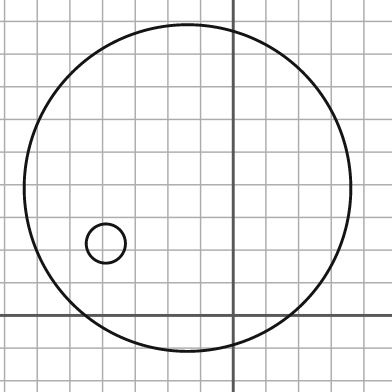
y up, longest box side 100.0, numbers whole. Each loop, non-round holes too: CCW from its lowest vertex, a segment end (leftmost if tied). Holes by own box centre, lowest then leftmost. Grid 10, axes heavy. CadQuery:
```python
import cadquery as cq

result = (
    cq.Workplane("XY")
    .moveTo(-14.0, 39.0)
    .circle(50.0)
    .moveTo(-39.0, 22.0)
    .circle(6.0)
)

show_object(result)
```